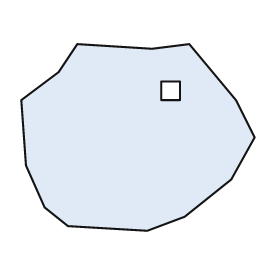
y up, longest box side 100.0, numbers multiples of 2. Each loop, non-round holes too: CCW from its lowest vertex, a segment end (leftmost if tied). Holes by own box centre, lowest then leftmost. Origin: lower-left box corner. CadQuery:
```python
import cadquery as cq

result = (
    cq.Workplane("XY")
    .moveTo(54.0, 0.0)
    .lineTo(70.0, 6.0)
    .lineTo(90.0, 22.0)
    .lineTo(100.0, 40.0)
    .lineTo(92.0, 56.0)
    .lineTo(72.0, 80.0)
    .lineTo(56.0, 78.0)
    .lineTo(24.0, 80.0)
    .lineTo(16.0, 68.0)
    .lineTo(0.0, 56.0)
    .lineTo(2.0, 28.0)
    .lineTo(10.0, 10.0)
    .lineTo(20.0, 2.0)
    .close()
    .moveTo(60.0, 56.0)
    .lineTo(68.0, 56.0)
    .lineTo(68.0, 64.0)
    .lineTo(60.0, 64.0)
    .close()
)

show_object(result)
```